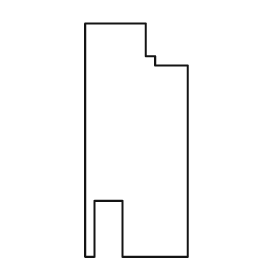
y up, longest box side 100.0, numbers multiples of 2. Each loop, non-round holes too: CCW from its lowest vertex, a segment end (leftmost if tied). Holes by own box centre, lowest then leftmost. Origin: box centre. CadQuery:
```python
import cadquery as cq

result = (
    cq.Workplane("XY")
    .moveTo(-22.0, -50.0)
    .lineTo(-18.0, -50.0)
    .lineTo(-18.0, -26.0)
    .lineTo(-6.0, -26.0)
    .lineTo(-6.0, -50.0)
    .lineTo(22.0, -50.0)
    .lineTo(22.0, 32.0)
    .lineTo(8.0, 32.0)
    .lineTo(8.0, 36.0)
    .lineTo(4.0, 36.0)
    .lineTo(4.0, 50.0)
    .lineTo(-22.0, 50.0)
    .close()
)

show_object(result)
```